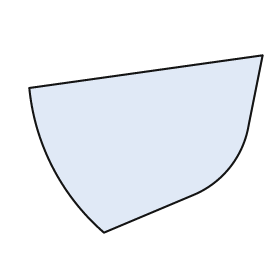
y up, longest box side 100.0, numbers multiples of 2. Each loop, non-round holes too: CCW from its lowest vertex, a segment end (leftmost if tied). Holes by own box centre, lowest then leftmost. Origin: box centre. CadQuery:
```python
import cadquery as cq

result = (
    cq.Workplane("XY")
    .moveTo(-18.0, -38.0)
    .lineTo(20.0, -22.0)
    .threePointArc((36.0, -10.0), (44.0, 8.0))
    .lineTo(50.0, 38.0)
    .lineTo(-50.0, 24.0)
    .threePointArc((-40.0, -10.0), (-18.0, -38.0))
    .close()
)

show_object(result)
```